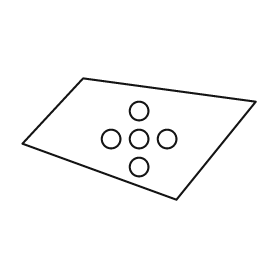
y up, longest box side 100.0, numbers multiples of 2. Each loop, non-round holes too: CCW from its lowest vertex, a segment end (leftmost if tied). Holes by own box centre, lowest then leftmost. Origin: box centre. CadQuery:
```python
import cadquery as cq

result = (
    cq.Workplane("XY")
    .moveTo(16.0, -26.0)
    .lineTo(50.0, 16.0)
    .lineTo(-24.0, 26.0)
    .lineTo(-50.0, -2.0)
    .close()
    .moveTo(0.0, -12.0)
    .circle(4.0)
    .moveTo(-12.0, 0.0)
    .circle(4.0)
    .moveTo(0.0, 0.0)
    .circle(4.0)
    .moveTo(12.0, 0.0)
    .circle(4.0)
    .moveTo(0.0, 12.0)
    .circle(4.0)
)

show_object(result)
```